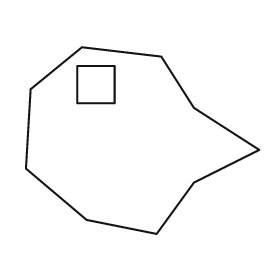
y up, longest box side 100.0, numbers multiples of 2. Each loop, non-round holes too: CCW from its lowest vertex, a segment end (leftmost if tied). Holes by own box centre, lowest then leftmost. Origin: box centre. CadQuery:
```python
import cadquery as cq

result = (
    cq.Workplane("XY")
    .moveTo(6.0, -40.0)
    .lineTo(22.0, -18.0)
    .lineTo(50.0, -4.0)
    .lineTo(22.0, 14.0)
    .lineTo(8.0, 36.0)
    .lineTo(-26.0, 40.0)
    .lineTo(-48.0, 22.0)
    .lineTo(-50.0, -12.0)
    .lineTo(-24.0, -34.0)
    .close()
    .moveTo(-28.0, 16.0)
    .lineTo(-12.0, 16.0)
    .lineTo(-12.0, 32.0)
    .lineTo(-28.0, 32.0)
    .close()
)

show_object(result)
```